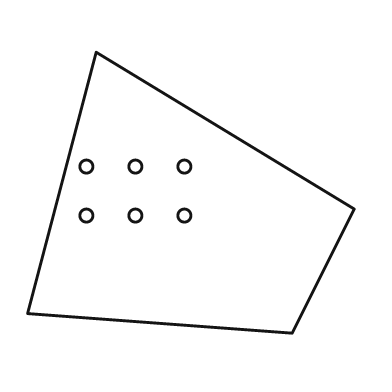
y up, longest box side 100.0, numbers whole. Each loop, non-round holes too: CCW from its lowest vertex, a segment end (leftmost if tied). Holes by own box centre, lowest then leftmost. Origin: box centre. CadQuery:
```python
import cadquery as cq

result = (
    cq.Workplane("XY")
    .moveTo(31.0, -43.0)
    .lineTo(50.0, -5.0)
    .lineTo(-29.0, 43.0)
    .lineTo(-50.0, -37.0)
    .close()
    .moveTo(-32.0, -7.0)
    .circle(2.0)
    .moveTo(-17.0, -7.0)
    .circle(2.0)
    .moveTo(-2.0, -7.0)
    .circle(2.0)
    .moveTo(-32.0, 8.0)
    .circle(2.0)
    .moveTo(-17.0, 8.0)
    .circle(2.0)
    .moveTo(-2.0, 8.0)
    .circle(2.0)
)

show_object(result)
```